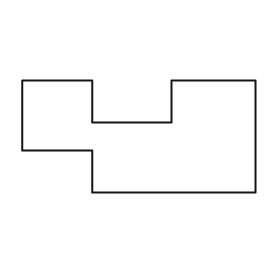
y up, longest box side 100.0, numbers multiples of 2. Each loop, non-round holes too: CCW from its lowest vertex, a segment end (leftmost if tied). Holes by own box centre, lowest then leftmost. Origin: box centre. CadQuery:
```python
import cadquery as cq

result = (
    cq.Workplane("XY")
    .moveTo(-20.0, -24.0)
    .lineTo(50.0, -24.0)
    .lineTo(50.0, 24.0)
    .lineTo(14.0, 24.0)
    .lineTo(14.0, 6.0)
    .lineTo(-20.0, 6.0)
    .lineTo(-20.0, 24.0)
    .lineTo(-50.0, 24.0)
    .lineTo(-50.0, -6.0)
    .lineTo(-20.0, -6.0)
    .close()
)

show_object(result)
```